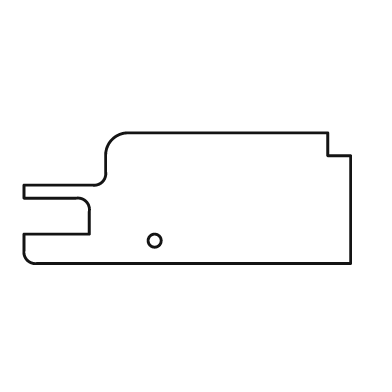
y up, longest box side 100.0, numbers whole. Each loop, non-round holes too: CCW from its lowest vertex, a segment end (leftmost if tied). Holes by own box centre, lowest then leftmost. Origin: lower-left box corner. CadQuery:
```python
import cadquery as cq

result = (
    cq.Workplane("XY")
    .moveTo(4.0, 0.0)
    .lineTo(100.0, 0.0)
    .lineTo(100.0, 33.0)
    .lineTo(93.0, 33.0)
    .lineTo(93.0, 40.0)
    .lineTo(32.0, 40.0)
    .threePointArc((27.0, 38.0), (25.0, 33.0))
    .lineTo(25.0, 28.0)
    .threePointArc((24.0, 25.0), (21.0, 24.0))
    .lineTo(0.0, 24.0)
    .lineTo(0.0, 20.0)
    .lineTo(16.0, 20.0)
    .threePointArc((19.0, 19.0), (20.0, 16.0))
    .lineTo(20.0, 9.0)
    .lineTo(0.0, 9.0)
    .lineTo(0.0, 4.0)
    .threePointArc((1.0, 1.0), (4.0, 0.0))
    .close()
    .moveTo(40.0, 7.0)
    .circle(2.0)
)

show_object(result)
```